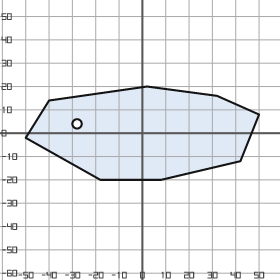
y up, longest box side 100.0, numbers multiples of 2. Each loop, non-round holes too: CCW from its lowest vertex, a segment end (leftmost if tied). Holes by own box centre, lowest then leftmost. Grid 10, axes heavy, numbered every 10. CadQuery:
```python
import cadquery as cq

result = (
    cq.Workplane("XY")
    .moveTo(-18.0, -20.0)
    .lineTo(8.0, -20.0)
    .lineTo(42.0, -12.0)
    .lineTo(50.0, 8.0)
    .lineTo(32.0, 16.0)
    .lineTo(2.0, 20.0)
    .lineTo(-40.0, 14.0)
    .lineTo(-50.0, -2.0)
    .close()
    .moveTo(-28.0, 4.0)
    .circle(2.0)
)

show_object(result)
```